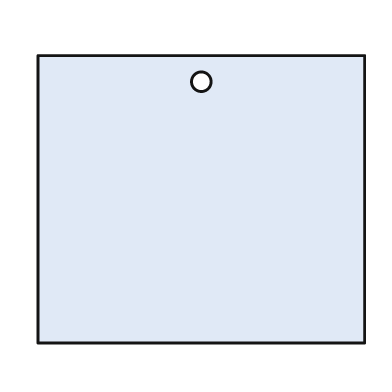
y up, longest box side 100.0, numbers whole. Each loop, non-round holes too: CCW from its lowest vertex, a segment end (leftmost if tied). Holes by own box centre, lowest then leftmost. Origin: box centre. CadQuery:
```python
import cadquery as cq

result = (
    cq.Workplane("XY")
    .moveTo(-50.0, -44.0)
    .lineTo(50.0, -44.0)
    .lineTo(50.0, 44.0)
    .lineTo(-50.0, 44.0)
    .close()
    .moveTo(0.0, 36.0)
    .circle(3.0)
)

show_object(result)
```